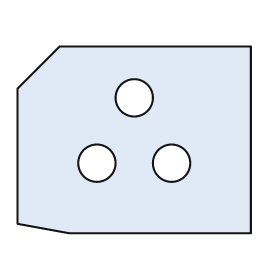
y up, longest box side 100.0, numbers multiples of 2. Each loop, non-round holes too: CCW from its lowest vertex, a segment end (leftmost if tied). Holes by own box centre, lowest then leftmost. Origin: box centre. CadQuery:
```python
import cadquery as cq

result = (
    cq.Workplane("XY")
    .moveTo(-28.0, -40.0)
    .lineTo(50.0, -40.0)
    .lineTo(50.0, 40.0)
    .lineTo(-32.0, 40.0)
    .lineTo(-50.0, 22.0)
    .lineTo(-50.0, -36.0)
    .close()
    .moveTo(-16.0, -10.0)
    .circle(8.0)
    .moveTo(16.0, -10.0)
    .circle(8.0)
    .moveTo(0.0, 18.0)
    .circle(8.0)
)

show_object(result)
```